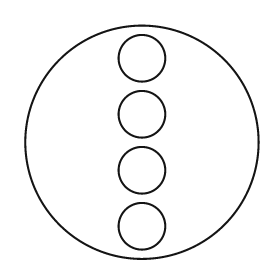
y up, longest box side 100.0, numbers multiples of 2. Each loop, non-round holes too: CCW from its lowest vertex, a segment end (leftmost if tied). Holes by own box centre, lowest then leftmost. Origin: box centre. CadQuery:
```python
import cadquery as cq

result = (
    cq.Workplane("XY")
    .moveTo(0.0, 0.0)
    .circle(50.0)
    .moveTo(0.0, -36.0)
    .circle(10.0)
    .moveTo(0.0, -12.0)
    .circle(10.0)
    .moveTo(0.0, 12.0)
    .circle(10.0)
    .moveTo(0.0, 36.0)
    .circle(10.0)
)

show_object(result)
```